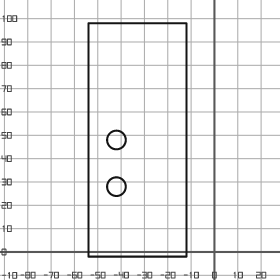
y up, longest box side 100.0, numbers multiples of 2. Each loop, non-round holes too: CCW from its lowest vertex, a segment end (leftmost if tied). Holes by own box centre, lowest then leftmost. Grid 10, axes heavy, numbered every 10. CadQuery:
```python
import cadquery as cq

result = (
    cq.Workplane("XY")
    .moveTo(-54.0, -2.0)
    .lineTo(-12.0, -2.0)
    .lineTo(-12.0, 98.0)
    .lineTo(-54.0, 98.0)
    .close()
    .moveTo(-42.0, 28.0)
    .circle(4.0)
    .moveTo(-42.0, 48.0)
    .circle(4.0)
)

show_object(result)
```